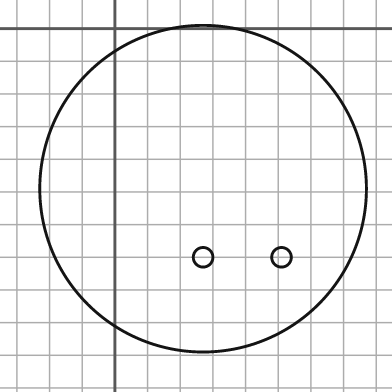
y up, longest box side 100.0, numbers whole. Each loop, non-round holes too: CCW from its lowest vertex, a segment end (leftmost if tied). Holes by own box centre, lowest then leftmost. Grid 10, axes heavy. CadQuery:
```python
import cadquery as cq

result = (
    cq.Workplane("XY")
    .moveTo(27.0, -49.0)
    .circle(50.0)
    .moveTo(27.0, -70.0)
    .circle(3.0)
    .moveTo(51.0, -70.0)
    .circle(3.0)
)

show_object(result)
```